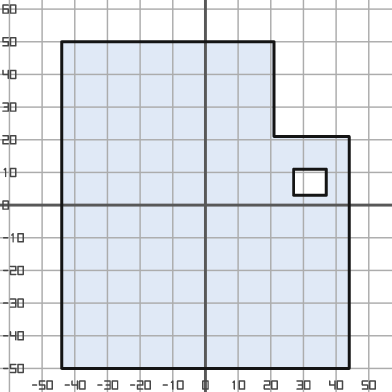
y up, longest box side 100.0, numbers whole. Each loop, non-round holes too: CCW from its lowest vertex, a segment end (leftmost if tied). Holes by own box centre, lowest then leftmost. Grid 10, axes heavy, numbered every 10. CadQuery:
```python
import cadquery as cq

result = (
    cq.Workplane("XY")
    .moveTo(-44.0, -50.0)
    .lineTo(44.0, -50.0)
    .lineTo(44.0, 21.0)
    .lineTo(21.0, 21.0)
    .lineTo(21.0, 50.0)
    .lineTo(-44.0, 50.0)
    .close()
    .moveTo(27.0, 3.0)
    .lineTo(37.0, 3.0)
    .lineTo(37.0, 11.0)
    .lineTo(27.0, 11.0)
    .close()
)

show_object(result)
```